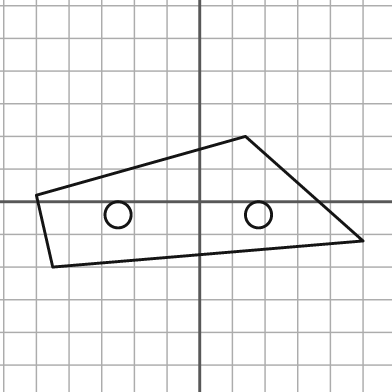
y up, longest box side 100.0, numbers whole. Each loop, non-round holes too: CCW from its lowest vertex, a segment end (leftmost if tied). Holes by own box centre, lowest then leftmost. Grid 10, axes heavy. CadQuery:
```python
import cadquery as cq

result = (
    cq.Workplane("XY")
    .moveTo(-45.0, -20.0)
    .lineTo(50.0, -12.0)
    .lineTo(14.0, 20.0)
    .lineTo(-50.0, 2.0)
    .close()
    .moveTo(-25.0, -4.0)
    .circle(4.0)
    .moveTo(18.0, -4.0)
    .circle(4.0)
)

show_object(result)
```